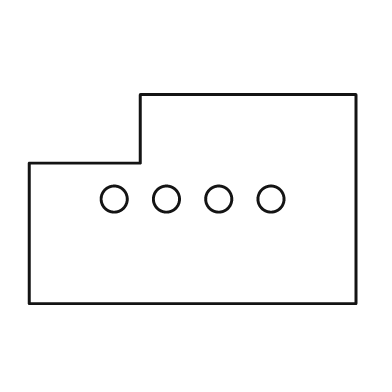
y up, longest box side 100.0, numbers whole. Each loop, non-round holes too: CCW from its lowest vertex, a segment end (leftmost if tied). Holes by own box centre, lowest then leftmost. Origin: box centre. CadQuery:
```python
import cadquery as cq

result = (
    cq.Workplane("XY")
    .moveTo(-50.0, -32.0)
    .lineTo(50.0, -32.0)
    .lineTo(50.0, 32.0)
    .lineTo(-16.0, 32.0)
    .lineTo(-16.0, 11.0)
    .lineTo(-50.0, 11.0)
    .close()
    .moveTo(-24.0, 0.0)
    .circle(4.0)
    .moveTo(-8.0, 0.0)
    .circle(4.0)
    .moveTo(8.0, 0.0)
    .circle(4.0)
    .moveTo(24.0, 0.0)
    .circle(4.0)
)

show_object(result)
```